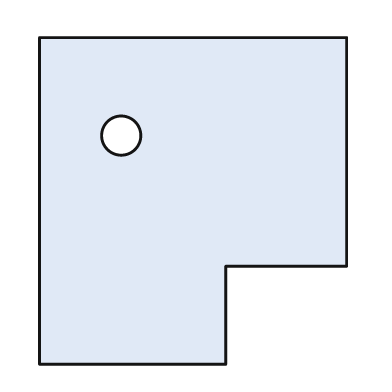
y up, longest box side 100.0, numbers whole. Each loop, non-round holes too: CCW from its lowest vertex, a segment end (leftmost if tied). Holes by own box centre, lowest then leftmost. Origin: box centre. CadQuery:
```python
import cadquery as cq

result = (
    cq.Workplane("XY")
    .moveTo(-47.0, -50.0)
    .lineTo(10.0, -50.0)
    .lineTo(10.0, -20.0)
    .lineTo(47.0, -20.0)
    .lineTo(47.0, 50.0)
    .lineTo(-47.0, 50.0)
    .close()
    .moveTo(-22.0, 20.0)
    .circle(6.0)
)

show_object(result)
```